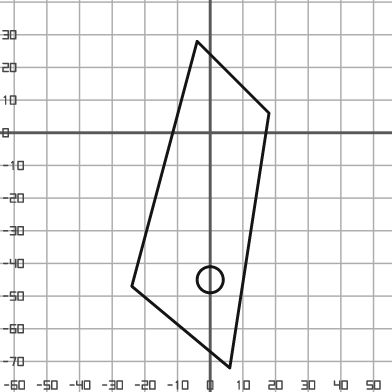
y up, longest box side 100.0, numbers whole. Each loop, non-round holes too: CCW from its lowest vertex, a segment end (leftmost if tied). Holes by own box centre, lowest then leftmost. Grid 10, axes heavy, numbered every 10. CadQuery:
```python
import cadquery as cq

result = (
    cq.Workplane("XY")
    .moveTo(6.0, -72.0)
    .lineTo(18.0, 6.0)
    .lineTo(-4.0, 28.0)
    .lineTo(-24.0, -47.0)
    .close()
    .moveTo(0.0, -45.0)
    .circle(4.0)
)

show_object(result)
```